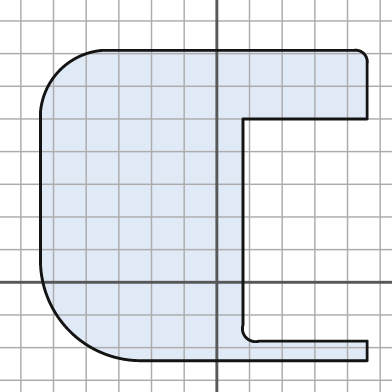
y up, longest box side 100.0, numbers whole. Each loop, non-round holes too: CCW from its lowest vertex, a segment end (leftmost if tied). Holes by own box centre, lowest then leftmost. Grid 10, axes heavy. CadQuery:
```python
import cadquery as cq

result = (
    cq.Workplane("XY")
    .moveTo(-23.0, -24.0)
    .lineTo(46.0, -24.0)
    .lineTo(46.0, -18.0)
    .lineTo(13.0, -18.0)
    .threePointArc((9.0, -17.0), (8.0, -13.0))
    .lineTo(8.0, 50.0)
    .lineTo(46.0, 50.0)
    .lineTo(46.0, 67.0)
    .threePointArc((45.0, 70.0), (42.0, 71.0))
    .lineTo(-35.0, 71.0)
    .threePointArc((-48.0, 65.0), (-54.0, 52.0))
    .lineTo(-54.0, 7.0)
    .threePointArc((-45.0, -15.0), (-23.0, -24.0))
    .close()
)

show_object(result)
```